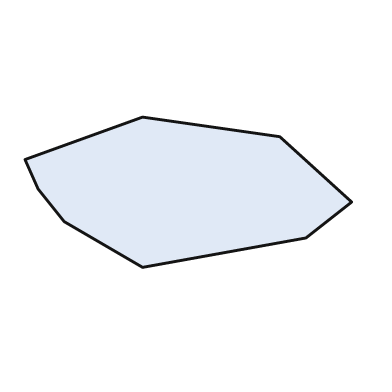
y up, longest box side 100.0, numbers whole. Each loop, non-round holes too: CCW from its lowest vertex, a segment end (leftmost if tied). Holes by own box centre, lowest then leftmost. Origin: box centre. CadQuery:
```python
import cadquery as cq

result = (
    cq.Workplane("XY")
    .moveTo(-14.0, -23.0)
    .lineTo(36.0, -14.0)
    .lineTo(50.0, -3.0)
    .lineTo(28.0, 17.0)
    .lineTo(-14.0, 23.0)
    .lineTo(-50.0, 10.0)
    .lineTo(-46.0, 1.0)
    .lineTo(-38.0, -9.0)
    .close()
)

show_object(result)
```